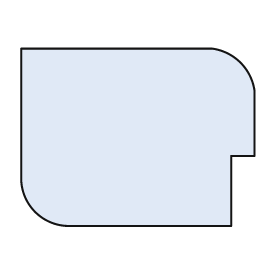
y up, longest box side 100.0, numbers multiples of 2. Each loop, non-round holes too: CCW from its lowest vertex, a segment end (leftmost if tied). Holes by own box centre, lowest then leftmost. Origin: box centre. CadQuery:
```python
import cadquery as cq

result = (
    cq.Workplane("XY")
    .moveTo(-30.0, -38.0)
    .lineTo(40.0, -38.0)
    .lineTo(40.0, -8.0)
    .lineTo(50.0, -8.0)
    .lineTo(50.0, 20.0)
    .threePointArc((44.0, 32.0), (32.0, 38.0))
    .lineTo(-50.0, 38.0)
    .lineTo(-50.0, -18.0)
    .threePointArc((-44.0, -32.0), (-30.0, -38.0))
    .close()
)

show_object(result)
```